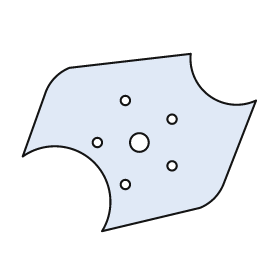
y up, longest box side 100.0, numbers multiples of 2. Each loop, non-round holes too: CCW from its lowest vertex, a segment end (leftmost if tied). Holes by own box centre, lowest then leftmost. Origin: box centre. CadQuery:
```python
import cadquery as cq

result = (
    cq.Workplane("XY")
    .moveTo(-16.0, -38.0)
    .lineTo(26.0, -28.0)
    .threePointArc((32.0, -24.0), (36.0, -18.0))
    .lineTo(50.0, 18.0)
    .threePointArc((30.0, 20.0), (22.0, 38.0))
    .lineTo(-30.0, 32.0)
    .threePointArc((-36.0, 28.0), (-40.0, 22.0))
    .lineTo(-50.0, -6.0)
    .threePointArc((-20.0, -8.0), (-16.0, -38.0))
    .close()
    .moveTo(-6.0, -18.0)
    .circle(2.0)
    .moveTo(14.0, -10.0)
    .circle(2.0)
    .moveTo(-18.0, 0.0)
    .circle(2.0)
    .moveTo(0.0, 0.0)
    .circle(4.0)
    .moveTo(14.0, 10.0)
    .circle(2.0)
    .moveTo(-6.0, 18.0)
    .circle(2.0)
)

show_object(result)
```